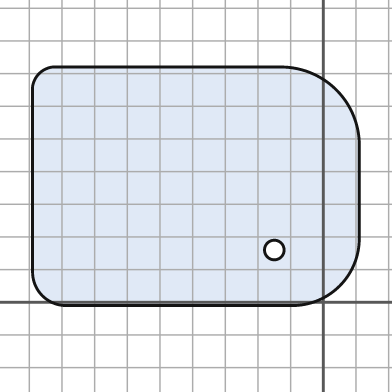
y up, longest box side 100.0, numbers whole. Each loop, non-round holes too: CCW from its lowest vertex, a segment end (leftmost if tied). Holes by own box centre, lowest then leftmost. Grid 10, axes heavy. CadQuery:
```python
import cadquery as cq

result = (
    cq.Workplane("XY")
    .moveTo(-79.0, -1.0)
    .lineTo(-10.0, -1.0)
    .threePointArc((5.0, 5.0), (11.0, 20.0))
    .lineTo(11.0, 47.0)
    .threePointArc((4.0, 65.0), (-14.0, 72.0))
    .lineTo(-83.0, 72.0)
    .threePointArc((-87.0, 70.0), (-89.0, 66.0))
    .lineTo(-89.0, 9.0)
    .threePointArc((-86.0, 2.0), (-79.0, -1.0))
    .close()
    .moveTo(-15.0, 16.0)
    .circle(3.0)
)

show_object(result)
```